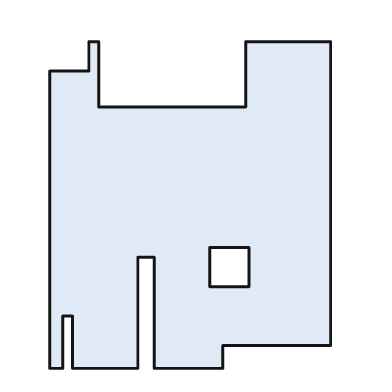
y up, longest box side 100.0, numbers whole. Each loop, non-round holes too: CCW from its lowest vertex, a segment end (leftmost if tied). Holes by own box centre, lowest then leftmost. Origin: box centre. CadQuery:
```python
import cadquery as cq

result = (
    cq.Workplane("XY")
    .moveTo(-43.0, -50.0)
    .lineTo(-39.0, -50.0)
    .lineTo(-39.0, -34.0)
    .lineTo(-36.0, -34.0)
    .lineTo(-36.0, -50.0)
    .lineTo(-16.0, -50.0)
    .lineTo(-16.0, -16.0)
    .lineTo(-11.0, -16.0)
    .lineTo(-11.0, -50.0)
    .lineTo(10.0, -50.0)
    .lineTo(10.0, -43.0)
    .lineTo(43.0, -43.0)
    .lineTo(43.0, 50.0)
    .lineTo(17.0, 50.0)
    .lineTo(17.0, 30.0)
    .lineTo(-28.0, 30.0)
    .lineTo(-28.0, 50.0)
    .lineTo(-31.0, 50.0)
    .lineTo(-31.0, 41.0)
    .lineTo(-43.0, 41.0)
    .close()
    .moveTo(6.0, -25.0)
    .lineTo(18.0, -25.0)
    .lineTo(18.0, -13.0)
    .lineTo(6.0, -13.0)
    .close()
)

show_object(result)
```